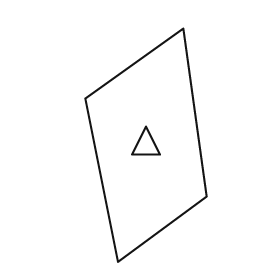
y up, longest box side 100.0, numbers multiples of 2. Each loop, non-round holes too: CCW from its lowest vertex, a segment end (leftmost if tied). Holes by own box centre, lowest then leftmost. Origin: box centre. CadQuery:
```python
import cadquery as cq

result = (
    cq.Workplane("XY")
    .moveTo(-12.0, -50.0)
    .lineTo(26.0, -22.0)
    .lineTo(16.0, 50.0)
    .lineTo(-26.0, 20.0)
    .close()
    .moveTo(-6.0, -4.0)
    .lineTo(6.0, -4.0)
    .lineTo(0.0, 8.0)
    .close()
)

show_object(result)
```